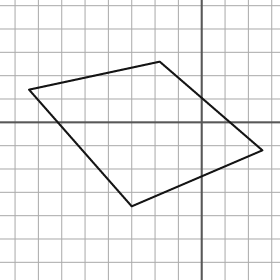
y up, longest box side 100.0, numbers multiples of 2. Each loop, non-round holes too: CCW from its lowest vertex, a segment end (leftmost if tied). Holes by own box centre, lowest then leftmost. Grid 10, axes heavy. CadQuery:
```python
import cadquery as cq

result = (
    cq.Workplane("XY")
    .moveTo(-30.0, -36.0)
    .lineTo(26.0, -12.0)
    .lineTo(-18.0, 26.0)
    .lineTo(-74.0, 14.0)
    .close()
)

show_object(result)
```